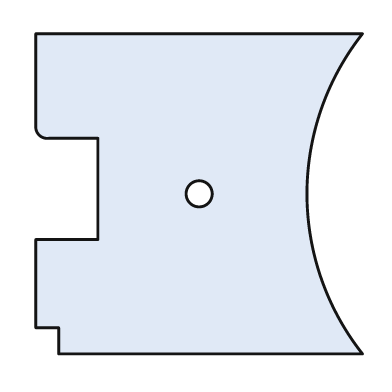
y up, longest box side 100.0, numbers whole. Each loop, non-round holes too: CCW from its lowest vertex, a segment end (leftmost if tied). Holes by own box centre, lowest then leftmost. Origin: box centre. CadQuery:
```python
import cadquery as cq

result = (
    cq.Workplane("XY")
    .moveTo(-43.0, -49.0)
    .lineTo(50.0, -49.0)
    .threePointArc((33.0, 0.0), (50.0, 49.0))
    .lineTo(-50.0, 49.0)
    .lineTo(-50.0, 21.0)
    .threePointArc((-49.0, 18.0), (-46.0, 17.0))
    .lineTo(-31.0, 17.0)
    .lineTo(-31.0, -14.0)
    .lineTo(-50.0, -14.0)
    .lineTo(-50.0, -41.0)
    .lineTo(-43.0, -41.0)
    .close()
    .moveTo(0.0, 0.0)
    .circle(4.0)
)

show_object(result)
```